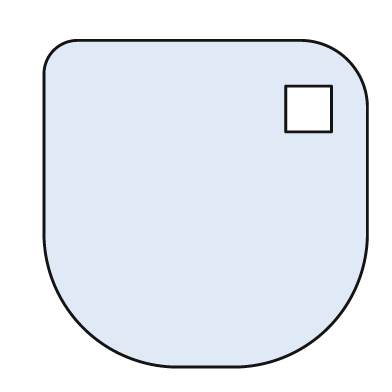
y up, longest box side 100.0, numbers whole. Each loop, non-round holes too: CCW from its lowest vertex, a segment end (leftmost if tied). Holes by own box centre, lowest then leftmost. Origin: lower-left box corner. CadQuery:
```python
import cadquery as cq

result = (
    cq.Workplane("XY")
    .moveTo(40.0, 0.0)
    .lineTo(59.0, 0.0)
    .threePointArc((87.0, 12.0), (99.0, 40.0))
    .lineTo(99.0, 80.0)
    .threePointArc((93.0, 94.0), (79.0, 100.0))
    .lineTo(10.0, 100.0)
    .threePointArc((3.0, 97.0), (0.0, 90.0))
    .lineTo(0.0, 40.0)
    .threePointArc((12.0, 12.0), (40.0, 0.0))
    .close()
    .moveTo(74.0, 72.0)
    .lineTo(88.0, 72.0)
    .lineTo(88.0, 86.0)
    .lineTo(74.0, 86.0)
    .close()
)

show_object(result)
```